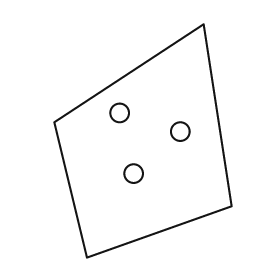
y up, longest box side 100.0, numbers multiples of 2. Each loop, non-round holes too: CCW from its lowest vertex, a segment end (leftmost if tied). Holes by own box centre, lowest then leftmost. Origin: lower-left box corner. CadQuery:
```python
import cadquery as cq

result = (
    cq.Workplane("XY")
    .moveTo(14.0, 0.0)
    .lineTo(76.0, 22.0)
    .lineTo(64.0, 100.0)
    .lineTo(0.0, 58.0)
    .close()
    .moveTo(34.0, 36.0)
    .circle(4.0)
    .moveTo(54.0, 54.0)
    .circle(4.0)
    .moveTo(28.0, 62.0)
    .circle(4.0)
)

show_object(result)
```